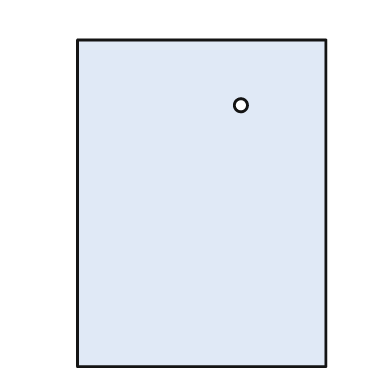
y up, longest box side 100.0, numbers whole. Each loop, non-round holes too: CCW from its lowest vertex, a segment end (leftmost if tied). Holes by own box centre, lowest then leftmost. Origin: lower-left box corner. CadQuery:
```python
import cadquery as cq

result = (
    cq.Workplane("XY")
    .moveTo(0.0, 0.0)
    .lineTo(76.0, 0.0)
    .lineTo(76.0, 100.0)
    .lineTo(0.0, 100.0)
    .close()
    .moveTo(50.0, 80.0)
    .circle(2.0)
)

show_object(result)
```